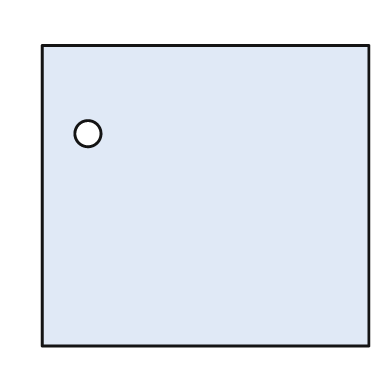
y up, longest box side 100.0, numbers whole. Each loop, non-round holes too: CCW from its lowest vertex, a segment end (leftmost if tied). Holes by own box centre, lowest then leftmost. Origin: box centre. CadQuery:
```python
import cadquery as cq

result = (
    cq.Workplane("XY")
    .moveTo(-50.0, -46.0)
    .lineTo(50.0, -46.0)
    .lineTo(50.0, 46.0)
    .lineTo(-50.0, 46.0)
    .close()
    .moveTo(-36.0, 19.0)
    .circle(4.0)
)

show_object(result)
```